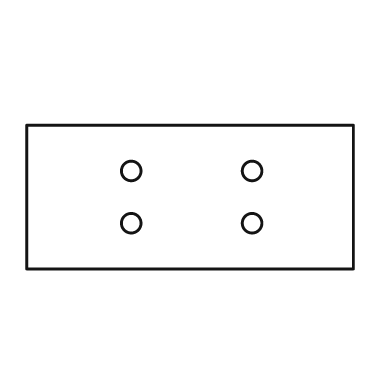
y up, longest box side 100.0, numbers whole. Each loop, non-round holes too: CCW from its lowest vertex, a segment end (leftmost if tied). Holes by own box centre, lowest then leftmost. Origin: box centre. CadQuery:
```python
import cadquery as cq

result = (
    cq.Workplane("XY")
    .moveTo(-50.0, -22.0)
    .lineTo(50.0, -22.0)
    .lineTo(50.0, 22.0)
    .lineTo(-50.0, 22.0)
    .close()
    .moveTo(-18.0, -8.0)
    .circle(3.0)
    .moveTo(19.0, -8.0)
    .circle(3.0)
    .moveTo(-18.0, 8.0)
    .circle(3.0)
    .moveTo(19.0, 8.0)
    .circle(3.0)
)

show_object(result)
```